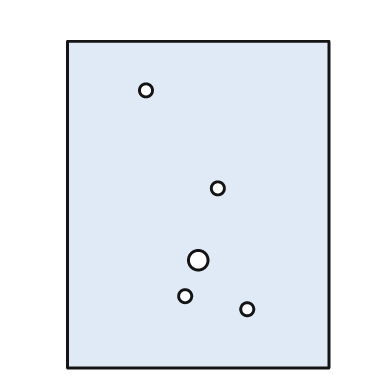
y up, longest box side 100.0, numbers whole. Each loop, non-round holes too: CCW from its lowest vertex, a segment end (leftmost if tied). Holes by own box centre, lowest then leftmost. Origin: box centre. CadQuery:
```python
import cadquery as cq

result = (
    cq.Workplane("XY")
    .moveTo(-40.0, -50.0)
    .lineTo(40.0, -50.0)
    .lineTo(40.0, 50.0)
    .lineTo(-40.0, 50.0)
    .close()
    .moveTo(15.0, -32.0)
    .circle(2.0)
    .moveTo(-4.0, -28.0)
    .circle(2.0)
    .moveTo(0.0, -17.0)
    .circle(3.0)
    .moveTo(6.0, 5.0)
    .circle(2.0)
    .moveTo(-16.0, 35.0)
    .circle(2.0)
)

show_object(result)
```